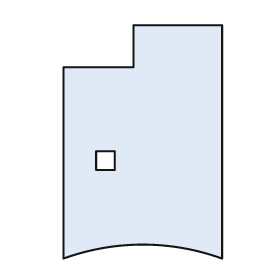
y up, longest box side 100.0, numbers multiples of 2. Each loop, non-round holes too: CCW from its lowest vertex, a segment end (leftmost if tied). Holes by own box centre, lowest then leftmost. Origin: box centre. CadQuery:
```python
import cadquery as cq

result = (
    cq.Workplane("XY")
    .moveTo(-34.0, -50.0)
    .threePointArc((0.0, -44.0), (34.0, -50.0))
    .lineTo(34.0, 50.0)
    .lineTo(-4.0, 50.0)
    .lineTo(-4.0, 32.0)
    .lineTo(-34.0, 32.0)
    .close()
    .moveTo(-20.0, -12.0)
    .lineTo(-12.0, -12.0)
    .lineTo(-12.0, -4.0)
    .lineTo(-20.0, -4.0)
    .close()
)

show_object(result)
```